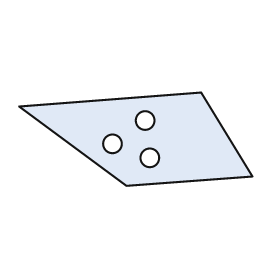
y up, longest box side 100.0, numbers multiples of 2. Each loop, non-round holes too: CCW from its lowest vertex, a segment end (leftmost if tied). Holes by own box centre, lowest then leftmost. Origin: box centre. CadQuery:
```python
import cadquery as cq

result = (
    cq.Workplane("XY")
    .moveTo(-4.0, -20.0)
    .lineTo(50.0, -16.0)
    .lineTo(28.0, 20.0)
    .lineTo(-50.0, 14.0)
    .close()
    .moveTo(6.0, -8.0)
    .circle(4.0)
    .moveTo(-10.0, -2.0)
    .circle(4.0)
    .moveTo(4.0, 8.0)
    .circle(4.0)
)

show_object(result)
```